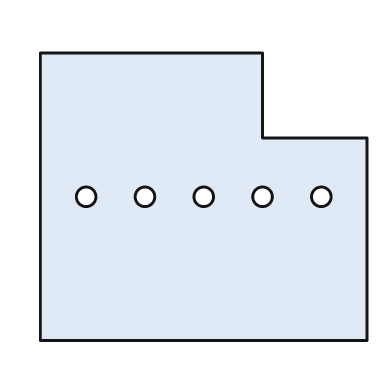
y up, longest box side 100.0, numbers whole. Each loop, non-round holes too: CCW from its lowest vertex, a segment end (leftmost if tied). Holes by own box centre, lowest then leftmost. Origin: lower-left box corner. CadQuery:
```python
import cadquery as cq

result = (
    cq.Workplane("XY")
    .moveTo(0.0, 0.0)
    .lineTo(100.0, 0.0)
    .lineTo(100.0, 62.0)
    .lineTo(68.0, 62.0)
    .lineTo(68.0, 88.0)
    .lineTo(0.0, 88.0)
    .close()
    .moveTo(14.0, 44.0)
    .circle(3.0)
    .moveTo(32.0, 44.0)
    .circle(3.0)
    .moveTo(50.0, 44.0)
    .circle(3.0)
    .moveTo(68.0, 44.0)
    .circle(3.0)
    .moveTo(86.0, 44.0)
    .circle(3.0)
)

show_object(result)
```